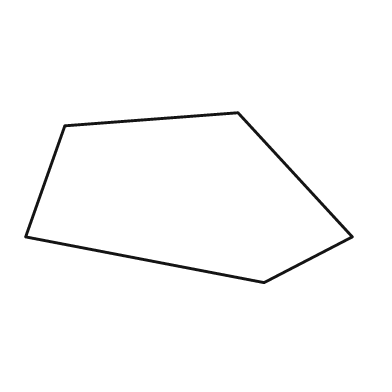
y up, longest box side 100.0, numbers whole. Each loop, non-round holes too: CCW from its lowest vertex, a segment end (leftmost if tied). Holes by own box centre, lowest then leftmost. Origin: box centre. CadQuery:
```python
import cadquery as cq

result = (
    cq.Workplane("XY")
    .moveTo(23.0, -26.0)
    .lineTo(50.0, -12.0)
    .lineTo(15.0, 26.0)
    .lineTo(-38.0, 22.0)
    .lineTo(-50.0, -12.0)
    .close()
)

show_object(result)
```